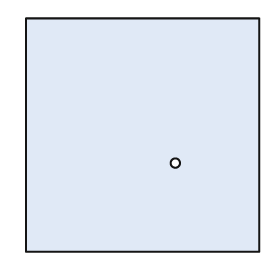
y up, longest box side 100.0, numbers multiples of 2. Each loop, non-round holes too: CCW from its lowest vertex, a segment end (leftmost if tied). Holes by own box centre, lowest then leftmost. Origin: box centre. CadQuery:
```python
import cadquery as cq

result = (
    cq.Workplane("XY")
    .moveTo(-50.0, -50.0)
    .lineTo(50.0, -50.0)
    .lineTo(50.0, 50.0)
    .lineTo(-50.0, 50.0)
    .close()
    .moveTo(14.0, -12.0)
    .circle(2.0)
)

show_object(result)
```